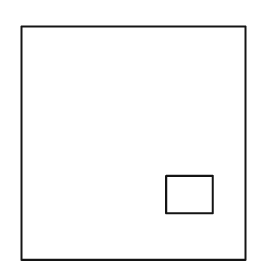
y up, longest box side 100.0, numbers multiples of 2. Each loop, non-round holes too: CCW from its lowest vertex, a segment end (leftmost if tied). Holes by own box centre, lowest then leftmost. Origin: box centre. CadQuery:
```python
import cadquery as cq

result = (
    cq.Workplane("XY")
    .moveTo(-48.0, -50.0)
    .lineTo(48.0, -50.0)
    .lineTo(48.0, 50.0)
    .lineTo(-48.0, 50.0)
    .close()
    .moveTo(14.0, -30.0)
    .lineTo(34.0, -30.0)
    .lineTo(34.0, -14.0)
    .lineTo(14.0, -14.0)
    .close()
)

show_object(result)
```